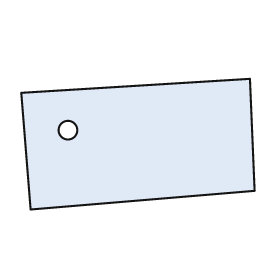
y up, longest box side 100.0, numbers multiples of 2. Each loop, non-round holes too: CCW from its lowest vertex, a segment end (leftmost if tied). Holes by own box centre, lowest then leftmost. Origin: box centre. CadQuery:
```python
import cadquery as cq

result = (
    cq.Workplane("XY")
    .moveTo(-46.0, -28.0)
    .lineTo(50.0, -20.0)
    .lineTo(48.0, 28.0)
    .lineTo(-50.0, 22.0)
    .close()
    .moveTo(-30.0, 6.0)
    .circle(4.0)
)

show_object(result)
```